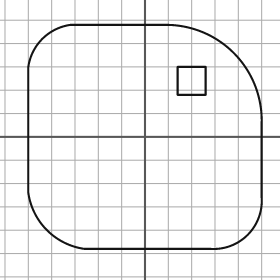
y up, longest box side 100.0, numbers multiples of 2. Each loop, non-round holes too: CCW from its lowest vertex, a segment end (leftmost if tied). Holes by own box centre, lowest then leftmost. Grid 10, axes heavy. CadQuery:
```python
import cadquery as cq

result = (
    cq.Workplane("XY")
    .moveTo(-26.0, -48.0)
    .lineTo(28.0, -48.0)
    .threePointArc((44.0, -42.0), (50.0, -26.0))
    .lineTo(50.0, 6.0)
    .threePointArc((38.0, 36.0), (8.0, 48.0))
    .lineTo(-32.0, 48.0)
    .threePointArc((-44.0, 42.0), (-50.0, 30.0))
    .lineTo(-50.0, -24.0)
    .threePointArc((-42.0, -40.0), (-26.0, -48.0))
    .close()
    .moveTo(14.0, 18.0)
    .lineTo(26.0, 18.0)
    .lineTo(26.0, 30.0)
    .lineTo(14.0, 30.0)
    .close()
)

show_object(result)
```